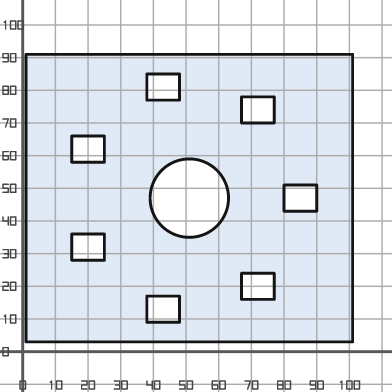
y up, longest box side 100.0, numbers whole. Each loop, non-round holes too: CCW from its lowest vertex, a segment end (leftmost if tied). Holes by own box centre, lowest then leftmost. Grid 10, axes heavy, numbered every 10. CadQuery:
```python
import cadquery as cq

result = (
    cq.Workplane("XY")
    .moveTo(1.0, 3.0)
    .lineTo(101.0, 3.0)
    .lineTo(101.0, 91.0)
    .lineTo(1.0, 91.0)
    .close()
    .moveTo(38.0, 9.0)
    .lineTo(48.0, 9.0)
    .lineTo(48.0, 17.0)
    .lineTo(38.0, 17.0)
    .close()
    .moveTo(67.0, 16.0)
    .lineTo(77.0, 16.0)
    .lineTo(77.0, 24.0)
    .lineTo(67.0, 24.0)
    .close()
    .moveTo(15.0, 28.0)
    .lineTo(25.0, 28.0)
    .lineTo(25.0, 36.0)
    .lineTo(15.0, 36.0)
    .close()
    .moveTo(51.0, 47.0)
    .circle(12.0)
    .moveTo(80.0, 43.0)
    .lineTo(90.0, 43.0)
    .lineTo(90.0, 51.0)
    .lineTo(80.0, 51.0)
    .close()
    .moveTo(15.0, 58.0)
    .lineTo(25.0, 58.0)
    .lineTo(25.0, 66.0)
    .lineTo(15.0, 66.0)
    .close()
    .moveTo(67.0, 70.0)
    .lineTo(77.0, 70.0)
    .lineTo(77.0, 78.0)
    .lineTo(67.0, 78.0)
    .close()
    .moveTo(38.0, 77.0)
    .lineTo(48.0, 77.0)
    .lineTo(48.0, 85.0)
    .lineTo(38.0, 85.0)
    .close()
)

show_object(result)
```